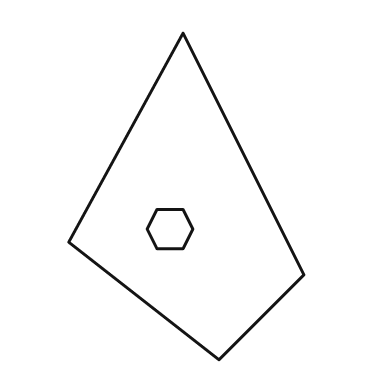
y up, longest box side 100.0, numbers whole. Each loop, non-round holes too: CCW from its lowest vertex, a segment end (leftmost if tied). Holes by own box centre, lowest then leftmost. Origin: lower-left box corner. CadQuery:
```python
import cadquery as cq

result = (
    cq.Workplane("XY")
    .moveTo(46.0, 0.0)
    .lineTo(72.0, 26.0)
    .lineTo(35.0, 100.0)
    .lineTo(0.0, 36.0)
    .close()
    .moveTo(27.0, 34.0)
    .lineTo(35.0, 34.0)
    .lineTo(38.0, 40.0)
    .lineTo(35.0, 46.0)
    .lineTo(27.0, 46.0)
    .lineTo(24.0, 40.0)
    .close()
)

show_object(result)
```